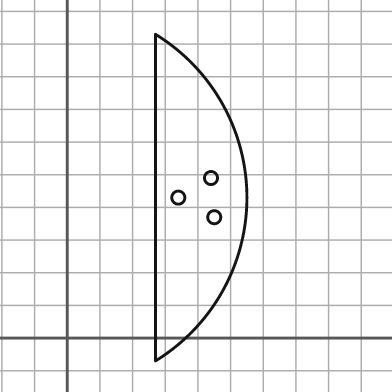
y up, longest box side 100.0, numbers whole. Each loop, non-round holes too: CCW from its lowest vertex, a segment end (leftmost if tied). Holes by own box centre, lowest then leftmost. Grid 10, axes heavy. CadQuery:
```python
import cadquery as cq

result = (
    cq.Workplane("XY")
    .moveTo(27.0, -7.0)
    .threePointArc((55.0, 43.0), (27.0, 93.0))
    .close()
    .moveTo(45.0, 37.0)
    .circle(2.0)
    .moveTo(34.0, 43.0)
    .circle(2.0)
    .moveTo(44.0, 49.0)
    .circle(2.0)
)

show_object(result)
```